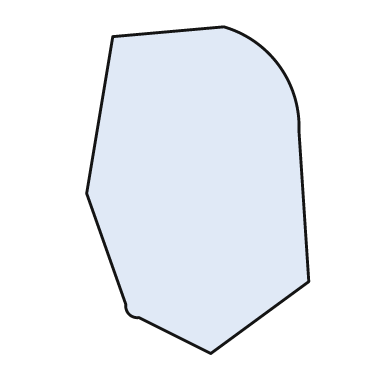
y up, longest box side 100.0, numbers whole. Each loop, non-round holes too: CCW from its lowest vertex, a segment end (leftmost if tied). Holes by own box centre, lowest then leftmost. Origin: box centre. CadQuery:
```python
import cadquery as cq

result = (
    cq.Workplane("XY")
    .moveTo(4.0, -50.0)
    .lineTo(34.0, -28.0)
    .lineTo(31.0, 18.0)
    .threePointArc((25.0, 38.0), (8.0, 50.0))
    .lineTo(-26.0, 47.0)
    .lineTo(-34.0, -1.0)
    .lineTo(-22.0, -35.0)
    .threePointArc((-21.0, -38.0), (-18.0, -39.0))
    .close()
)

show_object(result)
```